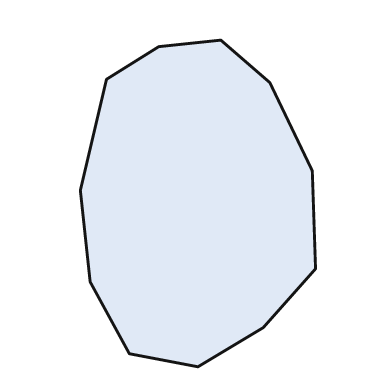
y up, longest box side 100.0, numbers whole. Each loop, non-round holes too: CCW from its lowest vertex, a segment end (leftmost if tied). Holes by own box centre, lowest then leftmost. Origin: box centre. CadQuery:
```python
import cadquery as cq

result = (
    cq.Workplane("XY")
    .moveTo(0.0, -50.0)
    .lineTo(20.0, -38.0)
    .lineTo(36.0, -20.0)
    .lineTo(35.0, 10.0)
    .lineTo(22.0, 37.0)
    .lineTo(7.0, 50.0)
    .lineTo(-12.0, 48.0)
    .lineTo(-28.0, 38.0)
    .lineTo(-36.0, 4.0)
    .lineTo(-33.0, -24.0)
    .lineTo(-21.0, -46.0)
    .close()
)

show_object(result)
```